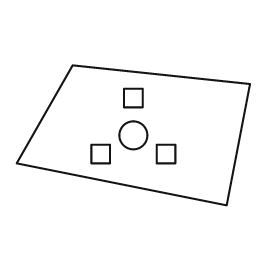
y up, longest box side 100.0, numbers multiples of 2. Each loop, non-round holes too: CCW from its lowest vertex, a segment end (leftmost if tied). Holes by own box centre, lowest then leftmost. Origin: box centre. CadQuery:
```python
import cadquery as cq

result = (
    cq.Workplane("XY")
    .moveTo(40.0, -30.0)
    .lineTo(50.0, 22.0)
    .lineTo(-26.0, 30.0)
    .lineTo(-50.0, -12.0)
    .close()
    .moveTo(-18.0, -12.0)
    .lineTo(-10.0, -12.0)
    .lineTo(-10.0, -4.0)
    .lineTo(-18.0, -4.0)
    .close()
    .moveTo(10.0, -12.0)
    .lineTo(18.0, -12.0)
    .lineTo(18.0, -4.0)
    .lineTo(10.0, -4.0)
    .close()
    .moveTo(0.0, 0.0)
    .circle(6.0)
    .moveTo(-4.0, 12.0)
    .lineTo(4.0, 12.0)
    .lineTo(4.0, 20.0)
    .lineTo(-4.0, 20.0)
    .close()
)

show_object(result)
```